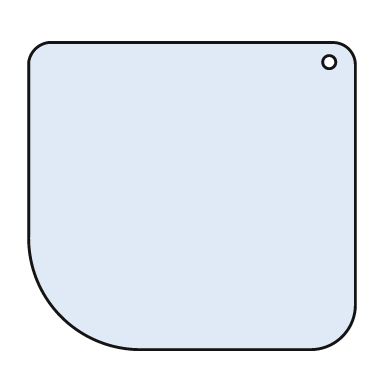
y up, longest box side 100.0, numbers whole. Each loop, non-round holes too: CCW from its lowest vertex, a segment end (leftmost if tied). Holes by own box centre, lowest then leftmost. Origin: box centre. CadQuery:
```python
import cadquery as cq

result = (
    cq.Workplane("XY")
    .moveTo(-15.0, -47.0)
    .lineTo(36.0, -47.0)
    .threePointArc((46.0, -43.0), (50.0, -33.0))
    .lineTo(50.0, 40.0)
    .threePointArc((48.0, 45.0), (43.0, 47.0))
    .lineTo(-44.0, 47.0)
    .threePointArc((-48.0, 45.0), (-50.0, 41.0))
    .lineTo(-50.0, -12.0)
    .threePointArc((-40.0, -37.0), (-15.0, -47.0))
    .close()
    .moveTo(42.0, 41.0)
    .circle(2.0)
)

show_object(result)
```